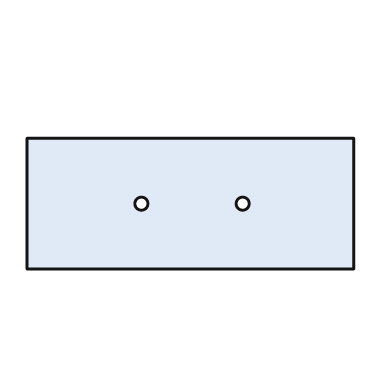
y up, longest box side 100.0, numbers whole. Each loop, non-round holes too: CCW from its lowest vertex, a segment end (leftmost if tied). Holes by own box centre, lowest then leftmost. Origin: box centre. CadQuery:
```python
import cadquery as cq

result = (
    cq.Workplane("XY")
    .moveTo(-50.0, -20.0)
    .lineTo(50.0, -20.0)
    .lineTo(50.0, 20.0)
    .lineTo(-50.0, 20.0)
    .close()
    .moveTo(-15.0, 0.0)
    .circle(2.0)
    .moveTo(16.0, 0.0)
    .circle(2.0)
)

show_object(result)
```